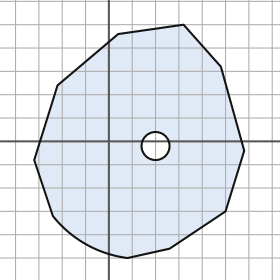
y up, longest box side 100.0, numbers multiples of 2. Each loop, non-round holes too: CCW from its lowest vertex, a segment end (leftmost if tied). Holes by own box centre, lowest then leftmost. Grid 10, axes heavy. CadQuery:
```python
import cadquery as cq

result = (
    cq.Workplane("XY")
    .moveTo(8.0, -50.0)
    .lineTo(26.0, -46.0)
    .lineTo(50.0, -30.0)
    .lineTo(58.0, -4.0)
    .lineTo(48.0, 32.0)
    .lineTo(32.0, 50.0)
    .lineTo(4.0, 46.0)
    .lineTo(-22.0, 24.0)
    .lineTo(-32.0, -8.0)
    .lineTo(-24.0, -32.0)
    .threePointArc((-10.0, -44.0), (8.0, -50.0))
    .close()
    .moveTo(20.0, -2.0)
    .circle(6.0)
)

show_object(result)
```